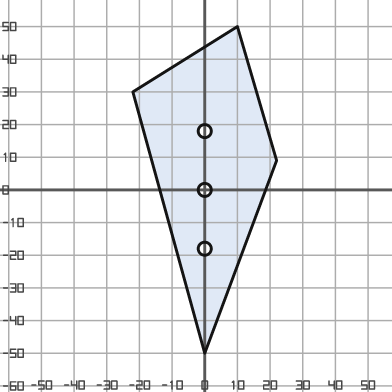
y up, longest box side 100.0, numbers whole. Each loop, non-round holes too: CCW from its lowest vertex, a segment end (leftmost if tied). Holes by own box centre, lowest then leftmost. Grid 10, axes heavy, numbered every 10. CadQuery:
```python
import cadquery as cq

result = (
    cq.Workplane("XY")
    .moveTo(0.0, -50.0)
    .lineTo(22.0, 9.0)
    .lineTo(10.0, 50.0)
    .lineTo(-22.0, 30.0)
    .close()
    .moveTo(0.0, -18.0)
    .circle(2.0)
    .moveTo(0.0, 0.0)
    .circle(2.0)
    .moveTo(0.0, 18.0)
    .circle(2.0)
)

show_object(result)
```